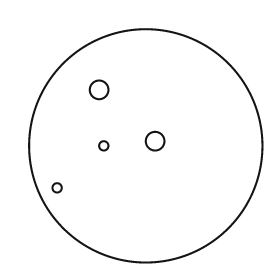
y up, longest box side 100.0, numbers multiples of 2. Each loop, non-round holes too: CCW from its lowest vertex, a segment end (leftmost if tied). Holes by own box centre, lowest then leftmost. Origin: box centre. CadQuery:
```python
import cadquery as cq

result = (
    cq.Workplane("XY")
    .moveTo(0.0, 0.0)
    .circle(50.0)
    .moveTo(-38.0, -18.0)
    .circle(2.0)
    .moveTo(-18.0, 0.0)
    .circle(2.0)
    .moveTo(4.0, 2.0)
    .circle(4.0)
    .moveTo(-20.0, 24.0)
    .circle(4.0)
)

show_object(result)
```